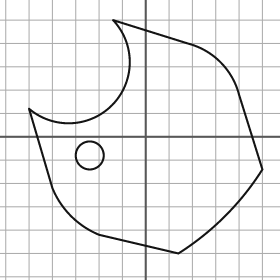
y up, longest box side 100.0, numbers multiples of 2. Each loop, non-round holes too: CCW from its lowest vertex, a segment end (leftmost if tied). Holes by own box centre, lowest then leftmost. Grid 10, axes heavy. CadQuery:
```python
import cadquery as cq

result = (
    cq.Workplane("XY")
    .moveTo(14.0, -50.0)
    .threePointArc((34.0, -34.0), (50.0, -14.0))
    .lineTo(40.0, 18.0)
    .threePointArc((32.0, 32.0), (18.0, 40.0))
    .lineTo(-14.0, 50.0)
    .threePointArc((-14.0, 14.0), (-50.0, 12.0))
    .lineTo(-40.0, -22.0)
    .threePointArc((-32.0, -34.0), (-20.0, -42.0))
    .close()
    .moveTo(-24.0, -8.0)
    .circle(6.0)
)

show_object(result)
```